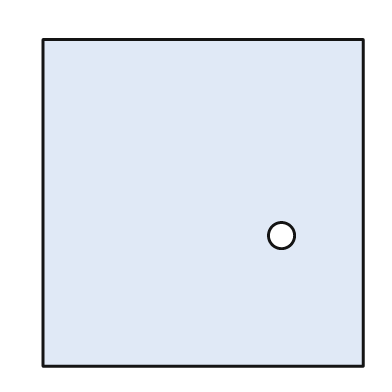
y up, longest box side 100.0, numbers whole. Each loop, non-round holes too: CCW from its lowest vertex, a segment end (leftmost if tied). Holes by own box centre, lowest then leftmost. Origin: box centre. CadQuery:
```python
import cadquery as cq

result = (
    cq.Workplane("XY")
    .moveTo(-49.0, -50.0)
    .lineTo(49.0, -50.0)
    .lineTo(49.0, 50.0)
    .lineTo(-49.0, 50.0)
    .close()
    .moveTo(24.0, -10.0)
    .circle(4.0)
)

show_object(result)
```